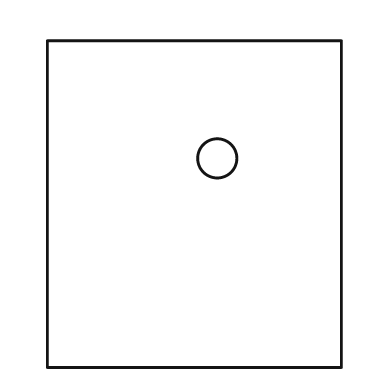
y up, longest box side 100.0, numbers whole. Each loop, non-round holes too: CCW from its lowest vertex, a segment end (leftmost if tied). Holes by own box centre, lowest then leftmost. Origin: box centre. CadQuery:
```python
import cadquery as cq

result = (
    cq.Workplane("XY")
    .moveTo(-45.0, -50.0)
    .lineTo(45.0, -50.0)
    .lineTo(45.0, 50.0)
    .lineTo(-45.0, 50.0)
    .close()
    .moveTo(7.0, 14.0)
    .circle(6.0)
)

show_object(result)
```